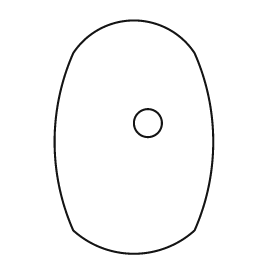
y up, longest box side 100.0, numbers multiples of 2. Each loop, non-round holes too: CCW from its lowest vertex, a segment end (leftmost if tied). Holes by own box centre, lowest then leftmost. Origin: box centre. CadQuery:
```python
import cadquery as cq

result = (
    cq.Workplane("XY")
    .moveTo(-26.0, -40.0)
    .threePointArc((0.0, -50.0), (26.0, -40.0))
    .threePointArc((34.0, -2.0), (26.0, 36.0))
    .threePointArc((0.0, 50.0), (-26.0, 36.0))
    .threePointArc((-34.0, -2.0), (-26.0, -40.0))
    .close()
    .moveTo(6.0, 6.0)
    .circle(6.0)
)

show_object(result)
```